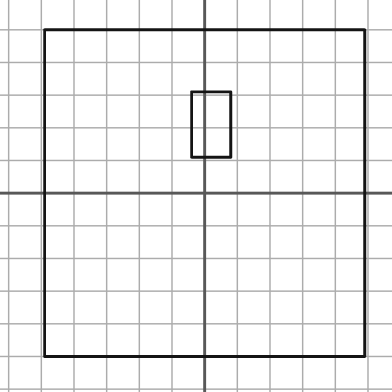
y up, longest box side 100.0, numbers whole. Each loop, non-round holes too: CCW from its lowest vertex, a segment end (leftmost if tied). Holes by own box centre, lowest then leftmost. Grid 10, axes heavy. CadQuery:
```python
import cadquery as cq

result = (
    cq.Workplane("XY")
    .moveTo(-49.0, -50.0)
    .lineTo(49.0, -50.0)
    .lineTo(49.0, 50.0)
    .lineTo(-49.0, 50.0)
    .close()
    .moveTo(-4.0, 11.0)
    .lineTo(8.0, 11.0)
    .lineTo(8.0, 31.0)
    .lineTo(-4.0, 31.0)
    .close()
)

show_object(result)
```